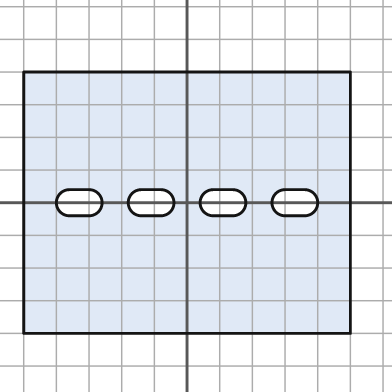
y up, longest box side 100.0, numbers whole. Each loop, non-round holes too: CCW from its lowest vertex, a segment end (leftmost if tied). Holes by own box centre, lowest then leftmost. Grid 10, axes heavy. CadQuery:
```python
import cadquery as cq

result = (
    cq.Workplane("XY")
    .moveTo(-50.0, -40.0)
    .lineTo(50.0, -40.0)
    .lineTo(50.0, 40.0)
    .lineTo(-50.0, 40.0)
    .close()
    .moveTo(-36.0, -4.0)
    .lineTo(-30.0, -4.0)
    .threePointArc((-26.0, 0.0), (-30.0, 4.0))
    .lineTo(-36.0, 4.0)
    .threePointArc((-40.0, 0.0), (-36.0, -4.0))
    .close()
    .moveTo(-14.0, -4.0)
    .lineTo(-8.0, -4.0)
    .threePointArc((-4.0, 0.0), (-8.0, 4.0))
    .lineTo(-14.0, 4.0)
    .threePointArc((-18.0, 0.0), (-14.0, -4.0))
    .close()
    .moveTo(8.0, -4.0)
    .lineTo(14.0, -4.0)
    .threePointArc((18.0, 0.0), (14.0, 4.0))
    .lineTo(8.0, 4.0)
    .threePointArc((4.0, 0.0), (8.0, -4.0))
    .close()
    .moveTo(30.0, -4.0)
    .lineTo(36.0, -4.0)
    .threePointArc((40.0, 0.0), (36.0, 4.0))
    .lineTo(30.0, 4.0)
    .threePointArc((26.0, 0.0), (30.0, -4.0))
    .close()
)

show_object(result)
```